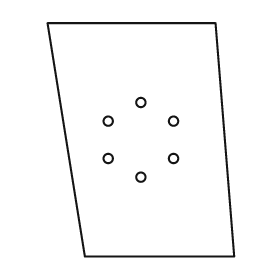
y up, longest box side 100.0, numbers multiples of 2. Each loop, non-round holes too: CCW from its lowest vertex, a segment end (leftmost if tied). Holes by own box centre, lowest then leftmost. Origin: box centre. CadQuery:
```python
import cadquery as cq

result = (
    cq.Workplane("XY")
    .moveTo(-24.0, -50.0)
    .lineTo(40.0, -50.0)
    .lineTo(32.0, 50.0)
    .lineTo(-40.0, 50.0)
    .close()
    .moveTo(0.0, -16.0)
    .circle(2.0)
    .moveTo(-14.0, -8.0)
    .circle(2.0)
    .moveTo(14.0, -8.0)
    .circle(2.0)
    .moveTo(-14.0, 8.0)
    .circle(2.0)
    .moveTo(14.0, 8.0)
    .circle(2.0)
    .moveTo(0.0, 16.0)
    .circle(2.0)
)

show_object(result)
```